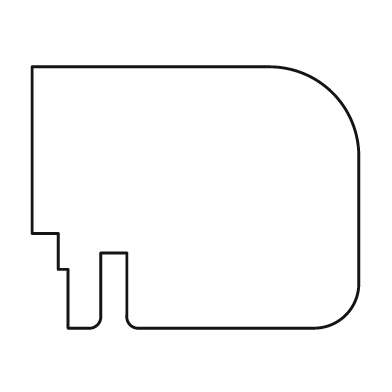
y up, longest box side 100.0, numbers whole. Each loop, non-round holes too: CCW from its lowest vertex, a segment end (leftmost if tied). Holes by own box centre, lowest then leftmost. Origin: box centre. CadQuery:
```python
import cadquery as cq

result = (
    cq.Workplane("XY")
    .moveTo(-39.0, -40.0)
    .lineTo(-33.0, -40.0)
    .threePointArc((-30.0, -39.0), (-29.0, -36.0))
    .lineTo(-29.0, -17.0)
    .lineTo(-21.0, -17.0)
    .lineTo(-21.0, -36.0)
    .threePointArc((-20.0, -39.0), (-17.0, -40.0))
    .lineTo(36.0, -40.0)
    .threePointArc((46.0, -36.0), (50.0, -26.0))
    .lineTo(50.0, 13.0)
    .threePointArc((42.0, 32.0), (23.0, 40.0))
    .lineTo(-50.0, 40.0)
    .lineTo(-50.0, -11.0)
    .lineTo(-42.0, -11.0)
    .lineTo(-42.0, -22.0)
    .lineTo(-39.0, -22.0)
    .close()
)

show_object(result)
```